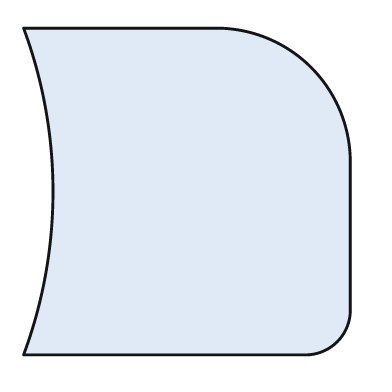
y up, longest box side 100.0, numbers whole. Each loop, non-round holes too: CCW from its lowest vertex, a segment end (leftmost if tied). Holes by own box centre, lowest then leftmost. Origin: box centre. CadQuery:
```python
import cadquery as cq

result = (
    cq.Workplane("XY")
    .moveTo(-50.0, -50.0)
    .lineTo(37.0, -50.0)
    .threePointArc((46.0, -46.0), (50.0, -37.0))
    .lineTo(50.0, 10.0)
    .threePointArc((38.0, 38.0), (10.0, 50.0))
    .lineTo(-50.0, 50.0)
    .threePointArc((-41.0, 0.0), (-50.0, -50.0))
    .close()
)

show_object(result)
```